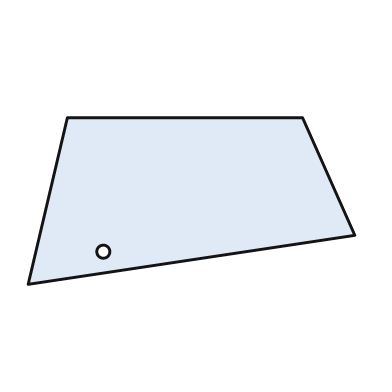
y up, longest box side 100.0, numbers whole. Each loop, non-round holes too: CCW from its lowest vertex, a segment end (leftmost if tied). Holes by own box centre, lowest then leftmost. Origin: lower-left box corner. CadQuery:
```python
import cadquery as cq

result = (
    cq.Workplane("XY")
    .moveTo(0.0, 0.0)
    .lineTo(100.0, 15.0)
    .lineTo(84.0, 51.0)
    .lineTo(12.0, 51.0)
    .close()
    .moveTo(23.0, 10.0)
    .circle(2.0)
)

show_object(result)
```